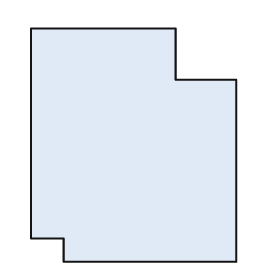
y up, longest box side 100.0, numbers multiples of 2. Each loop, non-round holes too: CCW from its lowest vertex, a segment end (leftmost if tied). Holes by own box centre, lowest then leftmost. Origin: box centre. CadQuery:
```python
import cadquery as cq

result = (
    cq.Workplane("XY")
    .moveTo(-30.0, -50.0)
    .lineTo(44.0, -50.0)
    .lineTo(44.0, 28.0)
    .lineTo(18.0, 28.0)
    .lineTo(18.0, 50.0)
    .lineTo(-44.0, 50.0)
    .lineTo(-44.0, -40.0)
    .lineTo(-30.0, -40.0)
    .close()
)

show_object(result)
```